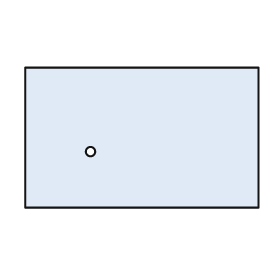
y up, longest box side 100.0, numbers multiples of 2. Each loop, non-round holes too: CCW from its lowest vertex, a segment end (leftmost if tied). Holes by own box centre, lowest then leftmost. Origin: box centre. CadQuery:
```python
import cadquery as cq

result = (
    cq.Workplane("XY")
    .moveTo(-50.0, -30.0)
    .lineTo(50.0, -30.0)
    .lineTo(50.0, 30.0)
    .lineTo(-50.0, 30.0)
    .close()
    .moveTo(-22.0, -6.0)
    .circle(2.0)
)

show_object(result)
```